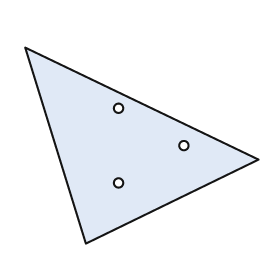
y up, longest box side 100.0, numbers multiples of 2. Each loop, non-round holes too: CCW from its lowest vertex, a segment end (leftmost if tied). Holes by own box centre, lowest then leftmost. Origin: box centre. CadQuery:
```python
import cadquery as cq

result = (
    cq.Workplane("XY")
    .moveTo(-24.0, -42.0)
    .lineTo(50.0, -6.0)
    .lineTo(-50.0, 42.0)
    .close()
    .moveTo(-10.0, -16.0)
    .circle(2.0)
    .moveTo(18.0, 0.0)
    .circle(2.0)
    .moveTo(-10.0, 16.0)
    .circle(2.0)
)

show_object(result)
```